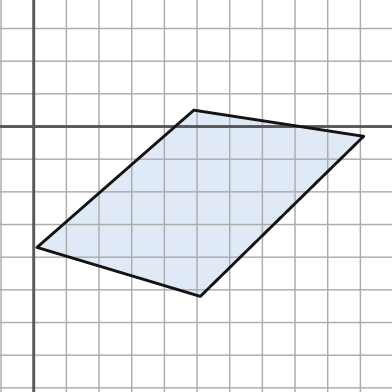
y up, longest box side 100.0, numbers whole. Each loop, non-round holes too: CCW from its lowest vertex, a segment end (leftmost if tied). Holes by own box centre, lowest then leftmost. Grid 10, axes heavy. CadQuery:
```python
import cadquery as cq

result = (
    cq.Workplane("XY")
    .moveTo(51.0, -52.0)
    .lineTo(101.0, -3.0)
    .lineTo(49.0, 5.0)
    .lineTo(1.0, -37.0)
    .close()
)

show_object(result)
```